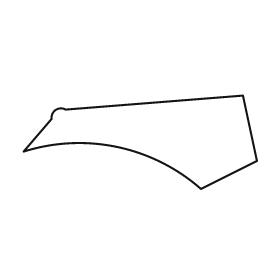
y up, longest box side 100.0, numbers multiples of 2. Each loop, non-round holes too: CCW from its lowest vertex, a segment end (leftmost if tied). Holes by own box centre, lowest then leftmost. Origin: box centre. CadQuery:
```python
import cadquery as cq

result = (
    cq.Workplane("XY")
    .moveTo(26.0, -20.0)
    .lineTo(50.0, -8.0)
    .lineTo(44.0, 20.0)
    .lineTo(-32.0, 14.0)
    .threePointArc((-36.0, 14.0), (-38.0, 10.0))
    .lineTo(-50.0, -4.0)
    .threePointArc((-10.0, -2.0), (26.0, -20.0))
    .close()
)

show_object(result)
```